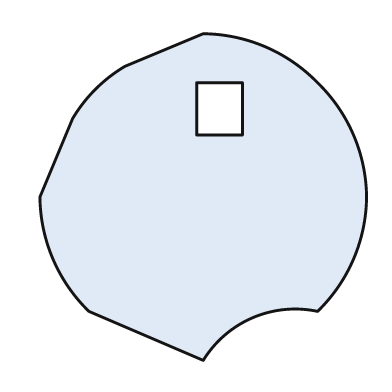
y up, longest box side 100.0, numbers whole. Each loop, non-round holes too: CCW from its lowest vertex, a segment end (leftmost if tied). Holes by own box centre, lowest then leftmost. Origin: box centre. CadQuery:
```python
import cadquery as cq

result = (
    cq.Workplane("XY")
    .moveTo(0.0, -50.0)
    .threePointArc((15.0, -37.0), (35.0, -35.0))
    .threePointArc((46.0, -19.0), (50.0, 0.0))
    .threePointArc((46.0, 19.0), (35.0, 35.0))
    .threePointArc((19.0, 46.0), (0.0, 50.0))
    .lineTo(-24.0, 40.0)
    .threePointArc((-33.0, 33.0), (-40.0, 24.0))
    .lineTo(-50.0, 0.0)
    .threePointArc((-46.0, -19.0), (-35.0, -35.0))
    .close()
    .moveTo(-2.0, 19.0)
    .lineTo(12.0, 19.0)
    .lineTo(12.0, 35.0)
    .lineTo(-2.0, 35.0)
    .close()
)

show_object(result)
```